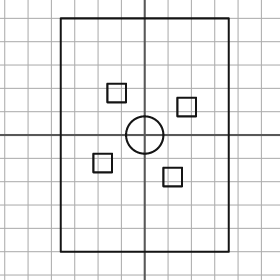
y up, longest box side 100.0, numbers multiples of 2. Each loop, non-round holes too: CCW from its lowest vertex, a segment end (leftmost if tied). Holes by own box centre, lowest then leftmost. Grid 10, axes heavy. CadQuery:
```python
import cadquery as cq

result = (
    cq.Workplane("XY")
    .moveTo(-36.0, -50.0)
    .lineTo(36.0, -50.0)
    .lineTo(36.0, 50.0)
    .lineTo(-36.0, 50.0)
    .close()
    .moveTo(8.0, -22.0)
    .lineTo(16.0, -22.0)
    .lineTo(16.0, -14.0)
    .lineTo(8.0, -14.0)
    .close()
    .moveTo(-22.0, -16.0)
    .lineTo(-14.0, -16.0)
    .lineTo(-14.0, -8.0)
    .lineTo(-22.0, -8.0)
    .close()
    .moveTo(0.0, 0.0)
    .circle(8.0)
    .moveTo(14.0, 8.0)
    .lineTo(22.0, 8.0)
    .lineTo(22.0, 16.0)
    .lineTo(14.0, 16.0)
    .close()
    .moveTo(-16.0, 14.0)
    .lineTo(-8.0, 14.0)
    .lineTo(-8.0, 22.0)
    .lineTo(-16.0, 22.0)
    .close()
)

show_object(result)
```